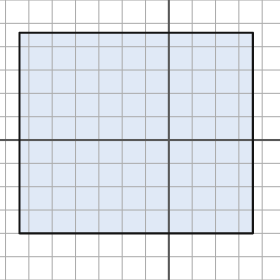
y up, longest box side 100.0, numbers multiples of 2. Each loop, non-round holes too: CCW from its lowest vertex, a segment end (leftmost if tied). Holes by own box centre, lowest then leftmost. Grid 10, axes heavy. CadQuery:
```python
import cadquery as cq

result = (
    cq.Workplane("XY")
    .moveTo(-64.0, -40.0)
    .lineTo(36.0, -40.0)
    .lineTo(36.0, 46.0)
    .lineTo(-64.0, 46.0)
    .close()
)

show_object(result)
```